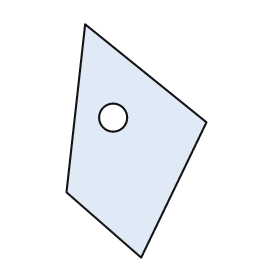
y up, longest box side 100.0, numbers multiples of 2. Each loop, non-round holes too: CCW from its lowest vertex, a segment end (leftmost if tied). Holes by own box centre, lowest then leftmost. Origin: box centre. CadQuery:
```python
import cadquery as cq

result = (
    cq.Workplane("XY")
    .moveTo(2.0, -50.0)
    .lineTo(30.0, 8.0)
    .lineTo(-22.0, 50.0)
    .lineTo(-30.0, -22.0)
    .close()
    .moveTo(-10.0, 10.0)
    .circle(6.0)
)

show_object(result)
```